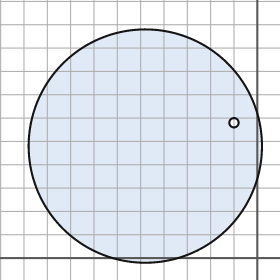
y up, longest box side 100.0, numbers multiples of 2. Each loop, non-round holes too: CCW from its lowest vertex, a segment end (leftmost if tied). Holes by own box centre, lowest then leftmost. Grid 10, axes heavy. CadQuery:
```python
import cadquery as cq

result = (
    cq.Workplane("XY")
    .moveTo(-48.0, 48.0)
    .circle(50.0)
    .moveTo(-10.0, 58.0)
    .circle(2.0)
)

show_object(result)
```